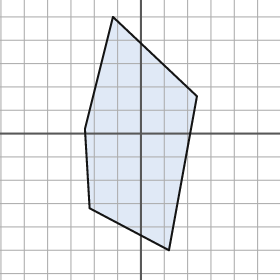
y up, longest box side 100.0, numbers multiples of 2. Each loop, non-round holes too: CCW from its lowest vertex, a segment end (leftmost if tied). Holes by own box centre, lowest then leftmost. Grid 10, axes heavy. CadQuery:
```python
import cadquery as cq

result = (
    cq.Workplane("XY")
    .moveTo(12.0, -50.0)
    .lineTo(24.0, 16.0)
    .lineTo(-12.0, 50.0)
    .lineTo(-24.0, 2.0)
    .lineTo(-22.0, -32.0)
    .close()
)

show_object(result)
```